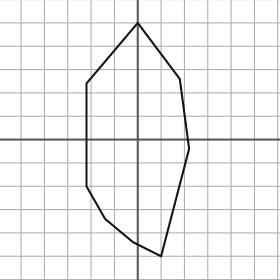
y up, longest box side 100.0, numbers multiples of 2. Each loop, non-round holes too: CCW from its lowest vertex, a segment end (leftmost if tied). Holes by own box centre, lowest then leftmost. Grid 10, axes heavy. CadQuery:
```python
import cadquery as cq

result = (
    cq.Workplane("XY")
    .moveTo(10.0, -50.0)
    .lineTo(22.0, -4.0)
    .lineTo(18.0, 26.0)
    .lineTo(0.0, 50.0)
    .lineTo(-22.0, 24.0)
    .lineTo(-22.0, -20.0)
    .lineTo(-14.0, -34.0)
    .lineTo(-2.0, -44.0)
    .close()
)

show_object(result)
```